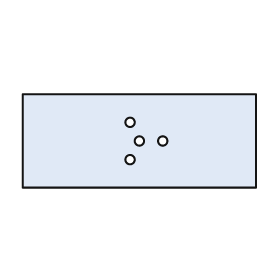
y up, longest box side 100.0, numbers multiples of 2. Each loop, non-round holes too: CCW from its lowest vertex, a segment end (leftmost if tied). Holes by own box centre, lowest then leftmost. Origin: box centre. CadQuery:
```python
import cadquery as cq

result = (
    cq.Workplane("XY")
    .moveTo(-50.0, -20.0)
    .lineTo(50.0, -20.0)
    .lineTo(50.0, 20.0)
    .lineTo(-50.0, 20.0)
    .close()
    .moveTo(-4.0, -8.0)
    .circle(2.0)
    .moveTo(0.0, 0.0)
    .circle(2.0)
    .moveTo(10.0, 0.0)
    .circle(2.0)
    .moveTo(-4.0, 8.0)
    .circle(2.0)
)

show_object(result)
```